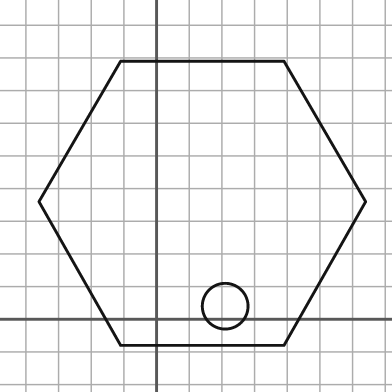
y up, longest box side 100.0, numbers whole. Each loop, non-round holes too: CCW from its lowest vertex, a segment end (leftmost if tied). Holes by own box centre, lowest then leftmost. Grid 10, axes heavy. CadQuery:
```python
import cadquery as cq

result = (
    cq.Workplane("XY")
    .moveTo(-11.0, -8.0)
    .lineTo(39.0, -8.0)
    .lineTo(64.0, 36.0)
    .lineTo(39.0, 79.0)
    .lineTo(-11.0, 79.0)
    .lineTo(-36.0, 36.0)
    .close()
    .moveTo(21.0, 4.0)
    .circle(7.0)
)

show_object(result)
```